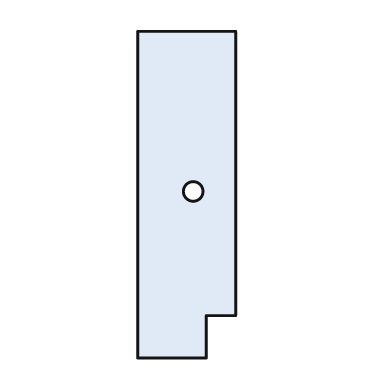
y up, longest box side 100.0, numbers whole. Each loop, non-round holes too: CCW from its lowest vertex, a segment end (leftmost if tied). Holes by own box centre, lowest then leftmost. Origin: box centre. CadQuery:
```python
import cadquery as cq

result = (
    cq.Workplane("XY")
    .moveTo(-15.0, -50.0)
    .lineTo(6.0, -50.0)
    .lineTo(6.0, -37.0)
    .lineTo(15.0, -37.0)
    .lineTo(15.0, 50.0)
    .lineTo(-15.0, 50.0)
    .close()
    .moveTo(2.0, 1.0)
    .circle(3.0)
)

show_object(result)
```